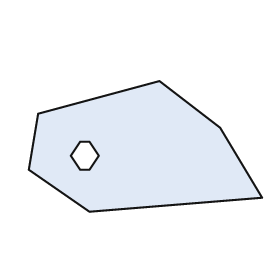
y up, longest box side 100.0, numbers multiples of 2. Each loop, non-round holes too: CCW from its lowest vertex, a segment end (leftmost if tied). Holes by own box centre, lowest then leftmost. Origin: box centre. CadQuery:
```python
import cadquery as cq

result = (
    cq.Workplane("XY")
    .moveTo(-24.0, -28.0)
    .lineTo(50.0, -22.0)
    .lineTo(32.0, 8.0)
    .lineTo(6.0, 28.0)
    .lineTo(-46.0, 14.0)
    .lineTo(-50.0, -10.0)
    .close()
    .moveTo(-28.0, -10.0)
    .lineTo(-24.0, -10.0)
    .lineTo(-20.0, -4.0)
    .lineTo(-24.0, 2.0)
    .lineTo(-28.0, 2.0)
    .lineTo(-32.0, -4.0)
    .close()
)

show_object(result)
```